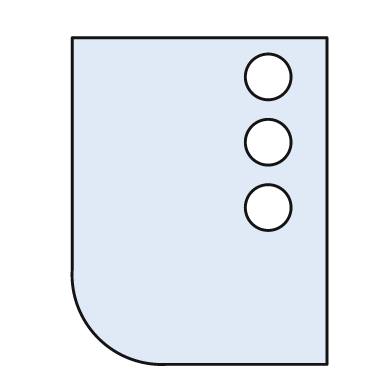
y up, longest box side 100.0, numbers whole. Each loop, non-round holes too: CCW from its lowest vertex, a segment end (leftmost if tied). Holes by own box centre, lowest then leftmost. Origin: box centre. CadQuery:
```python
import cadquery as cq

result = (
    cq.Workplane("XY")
    .moveTo(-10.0, -50.0)
    .lineTo(39.0, -50.0)
    .lineTo(39.0, 50.0)
    .lineTo(-39.0, 50.0)
    .lineTo(-39.0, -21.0)
    .threePointArc((-31.0, -42.0), (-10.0, -50.0))
    .close()
    .moveTo(21.0, -2.0)
    .circle(7.0)
    .moveTo(21.0, 18.0)
    .circle(7.0)
    .moveTo(21.0, 38.0)
    .circle(7.0)
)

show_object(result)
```